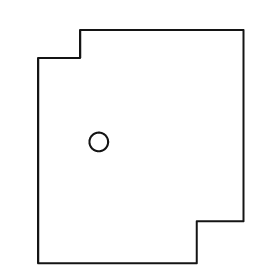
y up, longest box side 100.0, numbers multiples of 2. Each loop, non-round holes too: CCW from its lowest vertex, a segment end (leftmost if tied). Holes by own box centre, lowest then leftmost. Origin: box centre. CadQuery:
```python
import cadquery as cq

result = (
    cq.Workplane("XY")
    .moveTo(-44.0, -50.0)
    .lineTo(24.0, -50.0)
    .lineTo(24.0, -32.0)
    .lineTo(44.0, -32.0)
    .lineTo(44.0, 50.0)
    .lineTo(-26.0, 50.0)
    .lineTo(-26.0, 38.0)
    .lineTo(-44.0, 38.0)
    .close()
    .moveTo(-18.0, 2.0)
    .circle(4.0)
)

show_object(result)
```